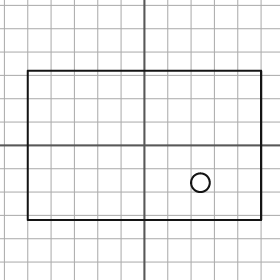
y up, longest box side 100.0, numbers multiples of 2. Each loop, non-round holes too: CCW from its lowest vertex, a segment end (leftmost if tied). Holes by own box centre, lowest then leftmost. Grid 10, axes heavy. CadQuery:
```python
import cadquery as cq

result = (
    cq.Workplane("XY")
    .moveTo(-50.0, -32.0)
    .lineTo(50.0, -32.0)
    .lineTo(50.0, 32.0)
    .lineTo(-50.0, 32.0)
    .close()
    .moveTo(24.0, -16.0)
    .circle(4.0)
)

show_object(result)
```